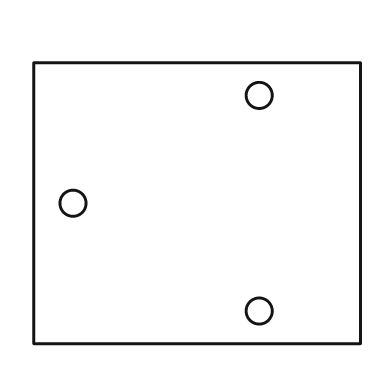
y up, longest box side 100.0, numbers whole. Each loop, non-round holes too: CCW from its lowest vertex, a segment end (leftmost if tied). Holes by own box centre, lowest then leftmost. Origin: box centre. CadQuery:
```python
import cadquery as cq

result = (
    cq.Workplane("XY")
    .moveTo(-50.0, -43.0)
    .lineTo(50.0, -43.0)
    .lineTo(50.0, 43.0)
    .lineTo(-50.0, 43.0)
    .close()
    .moveTo(19.0, -33.0)
    .circle(4.0)
    .moveTo(-38.0, 0.0)
    .circle(4.0)
    .moveTo(19.0, 33.0)
    .circle(4.0)
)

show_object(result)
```